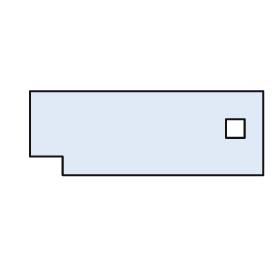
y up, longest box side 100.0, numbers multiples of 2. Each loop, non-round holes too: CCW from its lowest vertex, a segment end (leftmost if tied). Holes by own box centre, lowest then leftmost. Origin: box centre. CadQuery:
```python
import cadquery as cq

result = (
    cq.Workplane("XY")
    .moveTo(-36.0, -18.0)
    .lineTo(50.0, -18.0)
    .lineTo(50.0, 18.0)
    .lineTo(-50.0, 18.0)
    .lineTo(-50.0, -10.0)
    .lineTo(-36.0, -10.0)
    .close()
    .moveTo(34.0, -2.0)
    .lineTo(42.0, -2.0)
    .lineTo(42.0, 6.0)
    .lineTo(34.0, 6.0)
    .close()
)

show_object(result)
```